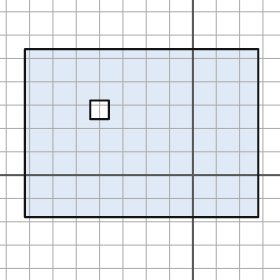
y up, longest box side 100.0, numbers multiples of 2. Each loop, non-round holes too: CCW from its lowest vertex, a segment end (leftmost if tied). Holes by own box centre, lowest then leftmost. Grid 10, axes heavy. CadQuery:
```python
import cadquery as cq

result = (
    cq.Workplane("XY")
    .moveTo(-72.0, -18.0)
    .lineTo(28.0, -18.0)
    .lineTo(28.0, 54.0)
    .lineTo(-72.0, 54.0)
    .close()
    .moveTo(-44.0, 24.0)
    .lineTo(-36.0, 24.0)
    .lineTo(-36.0, 32.0)
    .lineTo(-44.0, 32.0)
    .close()
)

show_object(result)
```